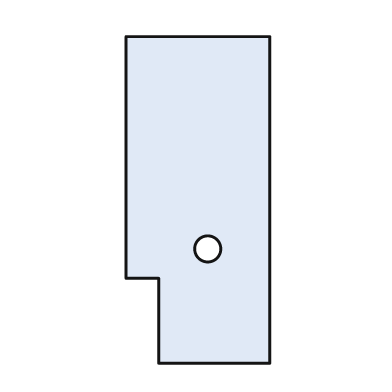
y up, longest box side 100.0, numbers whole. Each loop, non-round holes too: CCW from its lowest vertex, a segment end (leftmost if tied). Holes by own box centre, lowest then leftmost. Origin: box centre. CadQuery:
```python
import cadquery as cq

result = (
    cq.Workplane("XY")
    .moveTo(-12.0, -50.0)
    .lineTo(22.0, -50.0)
    .lineTo(22.0, 50.0)
    .lineTo(-22.0, 50.0)
    .lineTo(-22.0, -24.0)
    .lineTo(-12.0, -24.0)
    .close()
    .moveTo(3.0, -15.0)
    .circle(4.0)
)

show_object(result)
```